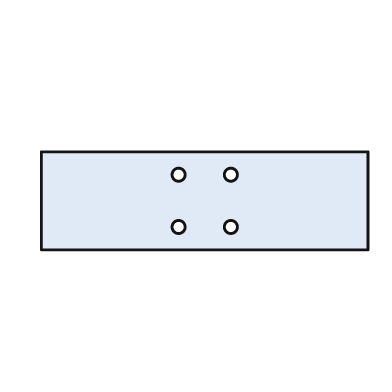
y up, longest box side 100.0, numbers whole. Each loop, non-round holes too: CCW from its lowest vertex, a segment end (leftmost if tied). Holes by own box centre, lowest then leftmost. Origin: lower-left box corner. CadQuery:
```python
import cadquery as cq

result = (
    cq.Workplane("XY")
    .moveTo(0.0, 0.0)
    .lineTo(100.0, 0.0)
    .lineTo(100.0, 30.0)
    .lineTo(0.0, 30.0)
    .close()
    .moveTo(42.0, 7.0)
    .circle(2.0)
    .moveTo(58.0, 7.0)
    .circle(2.0)
    .moveTo(42.0, 23.0)
    .circle(2.0)
    .moveTo(58.0, 23.0)
    .circle(2.0)
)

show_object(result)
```